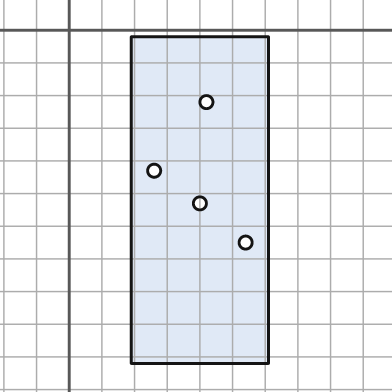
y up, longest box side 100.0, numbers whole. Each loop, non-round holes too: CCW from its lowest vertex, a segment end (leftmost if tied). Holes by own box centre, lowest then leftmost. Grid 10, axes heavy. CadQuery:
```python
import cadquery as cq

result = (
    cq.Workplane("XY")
    .moveTo(19.0, -102.0)
    .lineTo(61.0, -102.0)
    .lineTo(61.0, -2.0)
    .lineTo(19.0, -2.0)
    .close()
    .moveTo(54.0, -65.0)
    .circle(2.0)
    .moveTo(40.0, -53.0)
    .circle(2.0)
    .moveTo(26.0, -43.0)
    .circle(2.0)
    .moveTo(42.0, -22.0)
    .circle(2.0)
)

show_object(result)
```